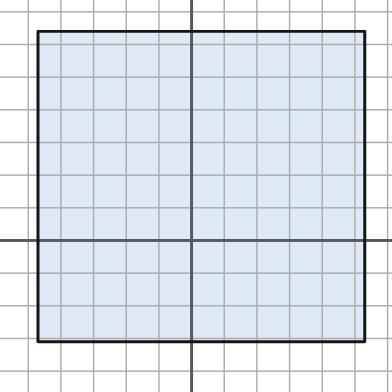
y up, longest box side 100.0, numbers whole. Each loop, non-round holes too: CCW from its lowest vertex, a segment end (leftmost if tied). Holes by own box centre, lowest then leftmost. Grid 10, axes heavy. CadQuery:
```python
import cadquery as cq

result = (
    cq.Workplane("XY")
    .moveTo(-47.0, -31.0)
    .lineTo(53.0, -31.0)
    .lineTo(53.0, 64.0)
    .lineTo(-47.0, 64.0)
    .close()
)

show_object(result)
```